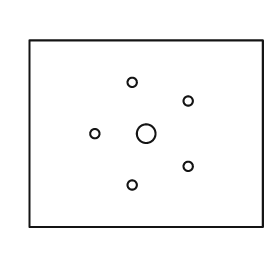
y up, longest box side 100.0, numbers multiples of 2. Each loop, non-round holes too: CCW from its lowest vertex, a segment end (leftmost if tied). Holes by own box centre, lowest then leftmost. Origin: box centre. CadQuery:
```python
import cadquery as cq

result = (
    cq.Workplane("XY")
    .moveTo(-50.0, -40.0)
    .lineTo(50.0, -40.0)
    .lineTo(50.0, 40.0)
    .lineTo(-50.0, 40.0)
    .close()
    .moveTo(-6.0, -22.0)
    .circle(2.0)
    .moveTo(18.0, -14.0)
    .circle(2.0)
    .moveTo(-22.0, 0.0)
    .circle(2.0)
    .moveTo(0.0, 0.0)
    .circle(4.0)
    .moveTo(18.0, 14.0)
    .circle(2.0)
    .moveTo(-6.0, 22.0)
    .circle(2.0)
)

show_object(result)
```